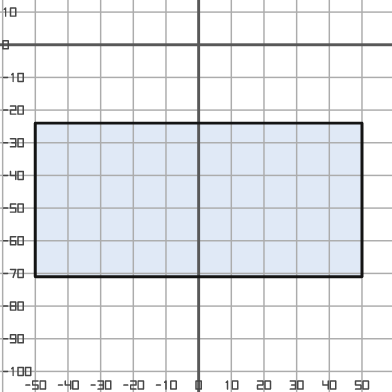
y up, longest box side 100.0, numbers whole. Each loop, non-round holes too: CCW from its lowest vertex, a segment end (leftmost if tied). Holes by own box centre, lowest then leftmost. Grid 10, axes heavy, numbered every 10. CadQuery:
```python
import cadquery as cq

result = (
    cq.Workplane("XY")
    .moveTo(-50.0, -71.0)
    .lineTo(50.0, -71.0)
    .lineTo(50.0, -24.0)
    .lineTo(-50.0, -24.0)
    .close()
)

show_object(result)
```